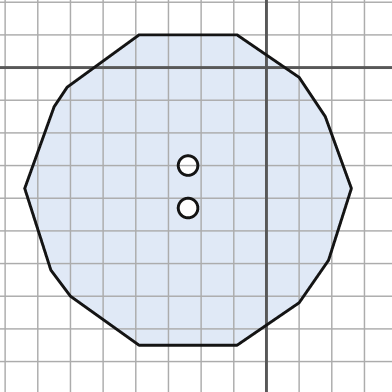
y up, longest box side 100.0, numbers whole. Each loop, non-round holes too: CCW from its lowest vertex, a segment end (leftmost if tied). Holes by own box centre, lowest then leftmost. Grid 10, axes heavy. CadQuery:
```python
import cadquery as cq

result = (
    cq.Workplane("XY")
    .moveTo(-39.0, -85.0)
    .lineTo(-9.0, -85.0)
    .lineTo(10.0, -72.0)
    .lineTo(19.0, -59.0)
    .lineTo(26.0, -37.0)
    .lineTo(18.0, -15.0)
    .lineTo(10.0, -3.0)
    .lineTo(-9.0, 10.0)
    .lineTo(-39.0, 10.0)
    .lineTo(-61.0, -6.0)
    .lineTo(-65.0, -12.0)
    .lineTo(-74.0, -37.0)
    .lineTo(-66.0, -62.0)
    .lineTo(-60.0, -70.0)
    .close()
    .moveTo(-24.0, -43.0)
    .circle(3.0)
    .moveTo(-24.0, -30.0)
    .circle(3.0)
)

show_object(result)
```